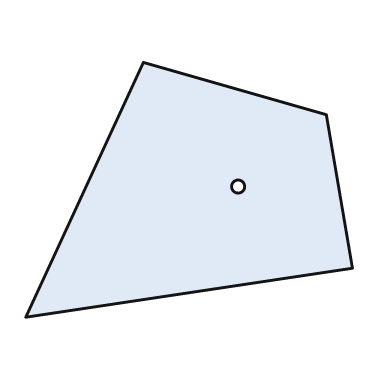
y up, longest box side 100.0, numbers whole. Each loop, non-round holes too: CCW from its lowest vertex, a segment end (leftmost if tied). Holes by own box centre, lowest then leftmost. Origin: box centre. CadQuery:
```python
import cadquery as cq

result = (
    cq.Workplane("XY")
    .moveTo(-50.0, -39.0)
    .lineTo(50.0, -24.0)
    .lineTo(42.0, 23.0)
    .lineTo(-14.0, 39.0)
    .close()
    .moveTo(15.0, 1.0)
    .circle(2.0)
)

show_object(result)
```